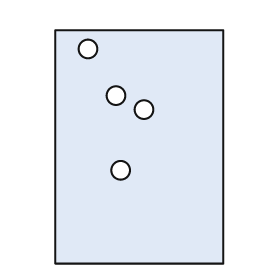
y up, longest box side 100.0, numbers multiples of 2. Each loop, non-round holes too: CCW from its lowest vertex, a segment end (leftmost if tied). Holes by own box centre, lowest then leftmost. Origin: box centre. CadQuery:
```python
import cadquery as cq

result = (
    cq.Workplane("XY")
    .moveTo(-36.0, -50.0)
    .lineTo(36.0, -50.0)
    .lineTo(36.0, 50.0)
    .lineTo(-36.0, 50.0)
    .close()
    .moveTo(-8.0, -10.0)
    .circle(4.0)
    .moveTo(2.0, 16.0)
    .circle(4.0)
    .moveTo(-10.0, 22.0)
    .circle(4.0)
    .moveTo(-22.0, 42.0)
    .circle(4.0)
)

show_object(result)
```